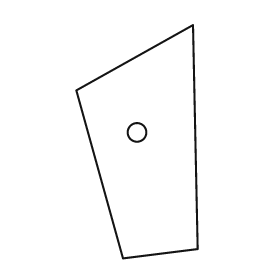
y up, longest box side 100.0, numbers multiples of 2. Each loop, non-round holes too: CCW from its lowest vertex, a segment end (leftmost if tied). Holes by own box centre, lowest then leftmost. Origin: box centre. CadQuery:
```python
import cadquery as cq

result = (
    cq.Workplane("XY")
    .moveTo(-6.0, -50.0)
    .lineTo(26.0, -46.0)
    .lineTo(24.0, 50.0)
    .lineTo(-26.0, 22.0)
    .close()
    .moveTo(0.0, 4.0)
    .circle(4.0)
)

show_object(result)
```